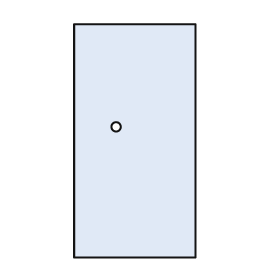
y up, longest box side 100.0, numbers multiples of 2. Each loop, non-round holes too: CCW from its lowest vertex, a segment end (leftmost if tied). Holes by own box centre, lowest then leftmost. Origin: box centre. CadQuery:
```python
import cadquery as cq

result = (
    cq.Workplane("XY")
    .moveTo(-26.0, -50.0)
    .lineTo(26.0, -50.0)
    .lineTo(26.0, 50.0)
    .lineTo(-26.0, 50.0)
    .close()
    .moveTo(-8.0, 6.0)
    .circle(2.0)
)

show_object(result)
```